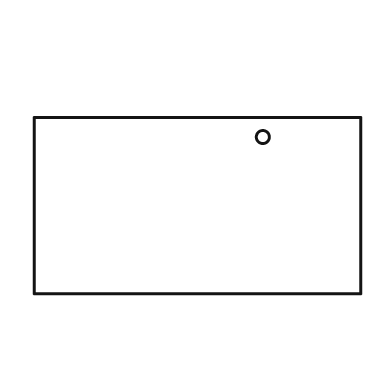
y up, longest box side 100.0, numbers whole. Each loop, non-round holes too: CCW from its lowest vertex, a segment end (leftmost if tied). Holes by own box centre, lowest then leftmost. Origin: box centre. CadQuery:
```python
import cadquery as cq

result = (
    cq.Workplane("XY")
    .moveTo(-50.0, -27.0)
    .lineTo(50.0, -27.0)
    .lineTo(50.0, 27.0)
    .lineTo(-50.0, 27.0)
    .close()
    .moveTo(20.0, 21.0)
    .circle(2.0)
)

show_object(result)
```